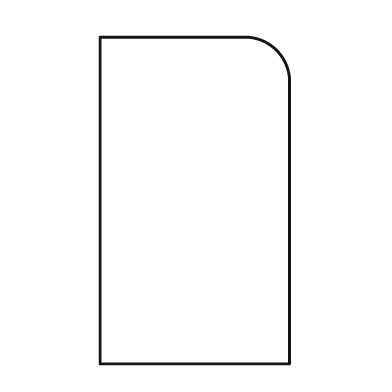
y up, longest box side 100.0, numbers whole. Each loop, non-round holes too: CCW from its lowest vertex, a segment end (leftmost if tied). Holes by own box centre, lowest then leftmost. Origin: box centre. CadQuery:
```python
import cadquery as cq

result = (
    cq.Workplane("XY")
    .moveTo(-29.0, -50.0)
    .lineTo(29.0, -50.0)
    .lineTo(29.0, 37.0)
    .threePointArc((25.0, 46.0), (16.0, 50.0))
    .lineTo(-29.0, 50.0)
    .close()
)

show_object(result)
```